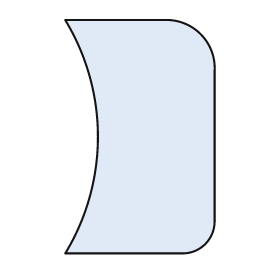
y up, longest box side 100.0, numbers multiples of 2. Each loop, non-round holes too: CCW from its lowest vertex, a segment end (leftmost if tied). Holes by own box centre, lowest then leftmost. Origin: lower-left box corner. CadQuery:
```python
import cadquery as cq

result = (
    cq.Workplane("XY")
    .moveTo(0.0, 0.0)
    .lineTo(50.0, 0.0)
    .threePointArc((60.0, 4.0), (64.0, 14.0))
    .lineTo(64.0, 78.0)
    .threePointArc((58.0, 94.0), (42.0, 100.0))
    .lineTo(0.0, 100.0)
    .threePointArc((14.0, 50.0), (0.0, 0.0))
    .close()
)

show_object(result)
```